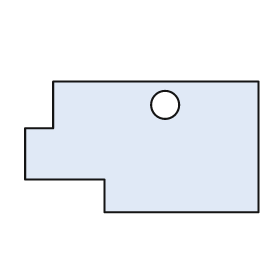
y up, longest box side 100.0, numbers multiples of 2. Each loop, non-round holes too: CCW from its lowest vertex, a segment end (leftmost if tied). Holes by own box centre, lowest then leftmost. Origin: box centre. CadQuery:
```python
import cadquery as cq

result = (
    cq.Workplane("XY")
    .moveTo(-16.0, -28.0)
    .lineTo(50.0, -28.0)
    .lineTo(50.0, 28.0)
    .lineTo(-38.0, 28.0)
    .lineTo(-38.0, 8.0)
    .lineTo(-50.0, 8.0)
    .lineTo(-50.0, -14.0)
    .lineTo(-16.0, -14.0)
    .close()
    .moveTo(10.0, 18.0)
    .circle(6.0)
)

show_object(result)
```